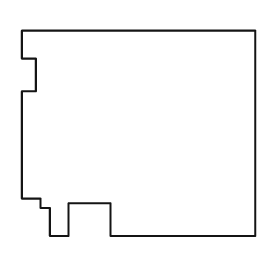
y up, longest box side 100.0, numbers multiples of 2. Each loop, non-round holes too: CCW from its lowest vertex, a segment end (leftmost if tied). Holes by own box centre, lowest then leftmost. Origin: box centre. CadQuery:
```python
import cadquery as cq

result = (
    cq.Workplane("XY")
    .moveTo(-38.0, -44.0)
    .lineTo(-30.0, -44.0)
    .lineTo(-30.0, -30.0)
    .lineTo(-12.0, -30.0)
    .lineTo(-12.0, -44.0)
    .lineTo(50.0, -44.0)
    .lineTo(50.0, 44.0)
    .lineTo(-50.0, 44.0)
    .lineTo(-50.0, 32.0)
    .lineTo(-44.0, 32.0)
    .lineTo(-44.0, 18.0)
    .lineTo(-50.0, 18.0)
    .lineTo(-50.0, -28.0)
    .lineTo(-42.0, -28.0)
    .lineTo(-42.0, -32.0)
    .lineTo(-38.0, -32.0)
    .close()
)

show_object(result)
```